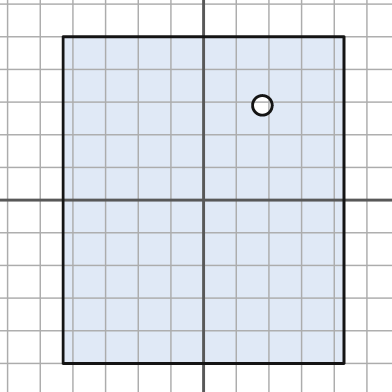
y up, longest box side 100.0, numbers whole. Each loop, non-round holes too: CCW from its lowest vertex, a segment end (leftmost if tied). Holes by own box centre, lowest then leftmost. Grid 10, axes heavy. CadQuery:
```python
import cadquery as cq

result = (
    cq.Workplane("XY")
    .moveTo(-43.0, -50.0)
    .lineTo(43.0, -50.0)
    .lineTo(43.0, 50.0)
    .lineTo(-43.0, 50.0)
    .close()
    .moveTo(18.0, 29.0)
    .circle(3.0)
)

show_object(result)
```